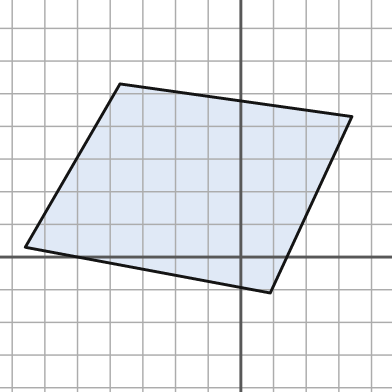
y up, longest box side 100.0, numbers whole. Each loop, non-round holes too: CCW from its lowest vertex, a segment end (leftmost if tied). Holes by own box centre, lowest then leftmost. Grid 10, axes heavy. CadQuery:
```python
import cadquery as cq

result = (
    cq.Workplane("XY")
    .moveTo(9.0, -11.0)
    .lineTo(34.0, 43.0)
    .lineTo(-37.0, 53.0)
    .lineTo(-66.0, 3.0)
    .close()
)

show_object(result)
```